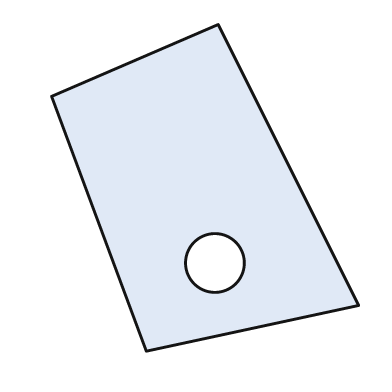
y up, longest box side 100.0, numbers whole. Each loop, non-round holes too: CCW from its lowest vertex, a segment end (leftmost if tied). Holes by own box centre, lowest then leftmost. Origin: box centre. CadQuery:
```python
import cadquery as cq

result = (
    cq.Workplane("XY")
    .moveTo(-18.0, -50.0)
    .lineTo(47.0, -36.0)
    .lineTo(4.0, 50.0)
    .lineTo(-47.0, 28.0)
    .close()
    .moveTo(3.0, -23.0)
    .circle(9.0)
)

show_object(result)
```